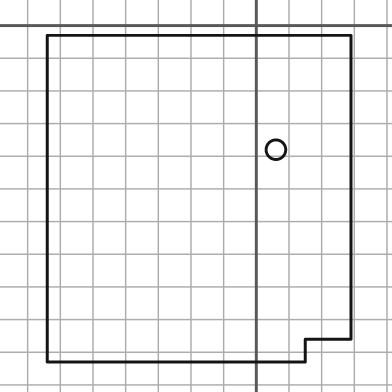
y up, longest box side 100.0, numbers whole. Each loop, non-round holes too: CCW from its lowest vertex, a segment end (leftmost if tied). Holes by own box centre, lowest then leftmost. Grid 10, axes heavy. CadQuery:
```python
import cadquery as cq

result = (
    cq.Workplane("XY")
    .moveTo(-64.0, -103.0)
    .lineTo(15.0, -103.0)
    .lineTo(15.0, -96.0)
    .lineTo(29.0, -96.0)
    .lineTo(29.0, -3.0)
    .lineTo(-64.0, -3.0)
    .close()
    .moveTo(6.0, -38.0)
    .circle(3.0)
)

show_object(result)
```